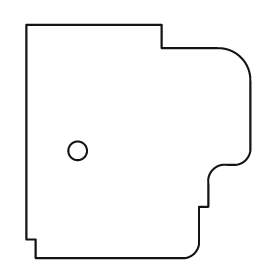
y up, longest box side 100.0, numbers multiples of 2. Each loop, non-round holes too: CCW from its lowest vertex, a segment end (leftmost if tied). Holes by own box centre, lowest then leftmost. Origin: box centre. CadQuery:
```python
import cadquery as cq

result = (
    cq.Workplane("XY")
    .moveTo(-44.0, -50.0)
    .lineTo(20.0, -50.0)
    .threePointArc((24.0, -48.0), (26.0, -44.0))
    .lineTo(26.0, -28.0)
    .lineTo(30.0, -28.0)
    .lineTo(30.0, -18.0)
    .threePointArc((32.0, -12.0), (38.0, -10.0))
    .lineTo(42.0, -10.0)
    .threePointArc((46.0, -8.0), (48.0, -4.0))
    .lineTo(48.0, 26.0)
    .threePointArc((44.0, 36.0), (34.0, 40.0))
    .lineTo(10.0, 40.0)
    .lineTo(10.0, 50.0)
    .lineTo(-48.0, 50.0)
    .lineTo(-48.0, -42.0)
    .lineTo(-44.0, -42.0)
    .close()
    .moveTo(-26.0, -4.0)
    .circle(4.0)
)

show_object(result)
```